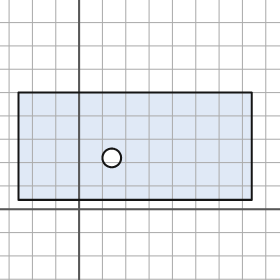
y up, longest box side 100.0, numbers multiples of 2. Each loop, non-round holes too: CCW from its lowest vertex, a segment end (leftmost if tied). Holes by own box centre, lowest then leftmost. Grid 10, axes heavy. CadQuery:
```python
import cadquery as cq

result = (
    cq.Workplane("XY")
    .moveTo(-26.0, 4.0)
    .lineTo(74.0, 4.0)
    .lineTo(74.0, 50.0)
    .lineTo(-26.0, 50.0)
    .close()
    .moveTo(14.0, 22.0)
    .circle(4.0)
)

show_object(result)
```